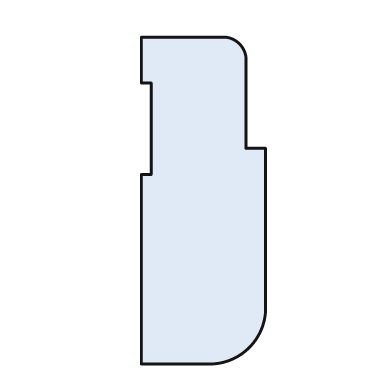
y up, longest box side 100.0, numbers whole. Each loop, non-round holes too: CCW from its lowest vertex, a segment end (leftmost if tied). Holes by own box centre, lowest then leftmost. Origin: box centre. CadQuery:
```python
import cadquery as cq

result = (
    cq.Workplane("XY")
    .moveTo(-19.0, -50.0)
    .lineTo(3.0, -50.0)
    .threePointArc((14.0, -45.0), (19.0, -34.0))
    .lineTo(19.0, 16.0)
    .lineTo(13.0, 16.0)
    .lineTo(13.0, 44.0)
    .threePointArc((11.0, 48.0), (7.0, 50.0))
    .lineTo(-19.0, 50.0)
    .lineTo(-19.0, 36.0)
    .lineTo(-16.0, 36.0)
    .lineTo(-16.0, 8.0)
    .lineTo(-19.0, 8.0)
    .close()
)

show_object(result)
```